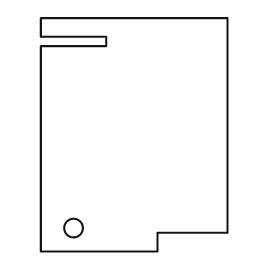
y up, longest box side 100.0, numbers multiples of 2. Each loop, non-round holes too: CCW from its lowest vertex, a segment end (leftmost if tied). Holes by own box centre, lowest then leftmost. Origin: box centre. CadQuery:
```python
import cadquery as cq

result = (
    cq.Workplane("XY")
    .moveTo(-40.0, -50.0)
    .lineTo(10.0, -50.0)
    .lineTo(10.0, -42.0)
    .lineTo(40.0, -42.0)
    .lineTo(40.0, 50.0)
    .lineTo(-40.0, 50.0)
    .lineTo(-40.0, 42.0)
    .lineTo(-12.0, 42.0)
    .lineTo(-12.0, 38.0)
    .lineTo(-40.0, 38.0)
    .close()
    .moveTo(-26.0, -40.0)
    .circle(4.0)
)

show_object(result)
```